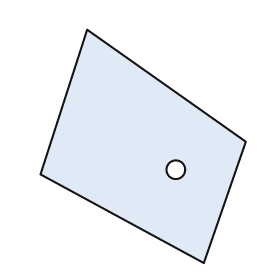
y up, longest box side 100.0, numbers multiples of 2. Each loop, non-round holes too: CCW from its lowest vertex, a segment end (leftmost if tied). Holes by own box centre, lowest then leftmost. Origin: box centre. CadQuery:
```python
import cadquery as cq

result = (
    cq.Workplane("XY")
    .moveTo(26.0, -50.0)
    .lineTo(44.0, 2.0)
    .lineTo(-24.0, 50.0)
    .lineTo(-44.0, -12.0)
    .close()
    .moveTo(14.0, -10.0)
    .circle(4.0)
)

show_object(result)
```